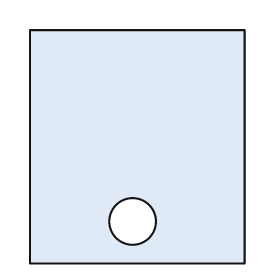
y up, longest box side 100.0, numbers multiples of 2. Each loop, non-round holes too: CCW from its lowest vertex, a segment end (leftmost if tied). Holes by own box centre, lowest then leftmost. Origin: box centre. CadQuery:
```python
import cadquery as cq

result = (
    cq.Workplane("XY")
    .moveTo(-46.0, -50.0)
    .lineTo(46.0, -50.0)
    .lineTo(46.0, 50.0)
    .lineTo(-46.0, 50.0)
    .close()
    .moveTo(-2.0, -32.0)
    .circle(10.0)
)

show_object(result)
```